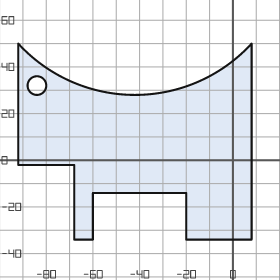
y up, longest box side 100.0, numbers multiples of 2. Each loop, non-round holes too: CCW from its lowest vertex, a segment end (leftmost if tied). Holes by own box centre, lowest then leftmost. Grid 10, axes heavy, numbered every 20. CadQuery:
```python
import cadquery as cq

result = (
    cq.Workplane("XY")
    .moveTo(-68.0, -34.0)
    .lineTo(-60.0, -34.0)
    .lineTo(-60.0, -14.0)
    .lineTo(-20.0, -14.0)
    .lineTo(-20.0, -34.0)
    .lineTo(8.0, -34.0)
    .lineTo(8.0, 50.0)
    .threePointArc((-42.0, 28.0), (-92.0, 50.0))
    .lineTo(-92.0, -2.0)
    .lineTo(-68.0, -2.0)
    .close()
    .moveTo(-84.0, 32.0)
    .circle(4.0)
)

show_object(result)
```